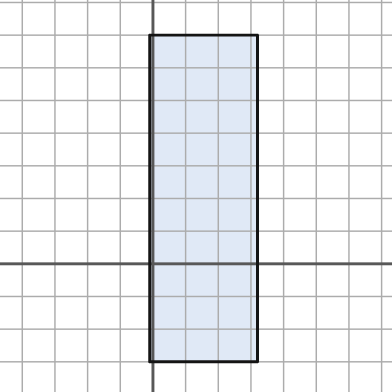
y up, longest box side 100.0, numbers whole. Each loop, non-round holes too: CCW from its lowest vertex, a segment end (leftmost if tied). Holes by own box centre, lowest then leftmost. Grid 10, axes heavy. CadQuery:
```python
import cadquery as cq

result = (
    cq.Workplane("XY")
    .moveTo(-1.0, -30.0)
    .lineTo(32.0, -30.0)
    .lineTo(32.0, 70.0)
    .lineTo(-1.0, 70.0)
    .close()
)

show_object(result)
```